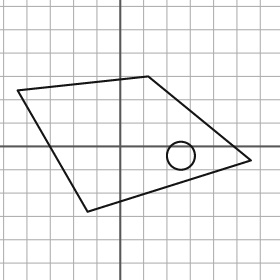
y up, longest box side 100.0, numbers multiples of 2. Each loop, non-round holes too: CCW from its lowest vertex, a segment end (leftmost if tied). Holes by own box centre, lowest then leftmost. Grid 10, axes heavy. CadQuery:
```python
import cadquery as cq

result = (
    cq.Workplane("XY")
    .moveTo(-14.0, -28.0)
    .lineTo(56.0, -6.0)
    .lineTo(12.0, 30.0)
    .lineTo(-44.0, 24.0)
    .close()
    .moveTo(26.0, -4.0)
    .circle(6.0)
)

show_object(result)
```